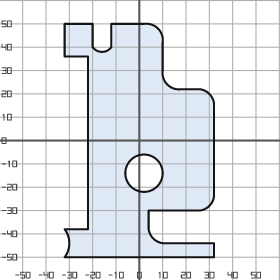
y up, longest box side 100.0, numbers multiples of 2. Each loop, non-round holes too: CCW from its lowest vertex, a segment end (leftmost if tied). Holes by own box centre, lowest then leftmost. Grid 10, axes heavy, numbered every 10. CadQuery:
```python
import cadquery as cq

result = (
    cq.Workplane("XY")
    .moveTo(-32.0, -50.0)
    .lineTo(32.0, -50.0)
    .lineTo(32.0, -44.0)
    .lineTo(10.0, -44.0)
    .threePointArc((6.0, -42.0), (4.0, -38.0))
    .lineTo(4.0, -30.0)
    .lineTo(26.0, -30.0)
    .threePointArc((30.0, -28.0), (32.0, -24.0))
    .lineTo(32.0, 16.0)
    .threePointArc((30.0, 20.0), (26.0, 22.0))
    .lineTo(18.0, 22.0)
    .threePointArc((12.0, 24.0), (10.0, 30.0))
    .lineTo(10.0, 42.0)
    .threePointArc((8.0, 48.0), (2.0, 50.0))
    .lineTo(-12.0, 50.0)
    .lineTo(-12.0, 40.0)
    .threePointArc((-16.0, 38.0), (-20.0, 40.0))
    .lineTo(-20.0, 50.0)
    .lineTo(-32.0, 50.0)
    .lineTo(-32.0, 36.0)
    .lineTo(-22.0, 36.0)
    .lineTo(-22.0, -38.0)
    .lineTo(-32.0, -38.0)
    .threePointArc((-30.0, -44.0), (-32.0, -50.0))
    .close()
    .moveTo(2.0, -14.0)
    .circle(8.0)
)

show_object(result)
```